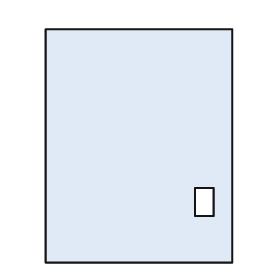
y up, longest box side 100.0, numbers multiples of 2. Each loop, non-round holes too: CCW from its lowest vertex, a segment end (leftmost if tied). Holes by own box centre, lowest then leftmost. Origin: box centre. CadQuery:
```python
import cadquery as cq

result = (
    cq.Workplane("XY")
    .moveTo(-40.0, -50.0)
    .lineTo(40.0, -50.0)
    .lineTo(40.0, 50.0)
    .lineTo(-40.0, 50.0)
    .close()
    .moveTo(24.0, -30.0)
    .lineTo(32.0, -30.0)
    .lineTo(32.0, -18.0)
    .lineTo(24.0, -18.0)
    .close()
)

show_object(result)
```